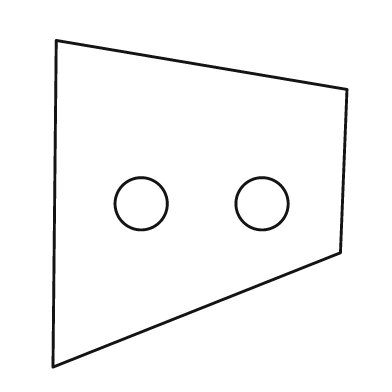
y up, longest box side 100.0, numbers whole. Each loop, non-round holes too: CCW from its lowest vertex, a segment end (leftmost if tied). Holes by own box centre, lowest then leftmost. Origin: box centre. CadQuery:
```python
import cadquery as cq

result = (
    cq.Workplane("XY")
    .moveTo(-45.0, -50.0)
    .lineTo(43.0, -15.0)
    .lineTo(45.0, 35.0)
    .lineTo(-44.0, 50.0)
    .close()
    .moveTo(-18.0, 0.0)
    .circle(8.0)
    .moveTo(19.0, 0.0)
    .circle(8.0)
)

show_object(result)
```